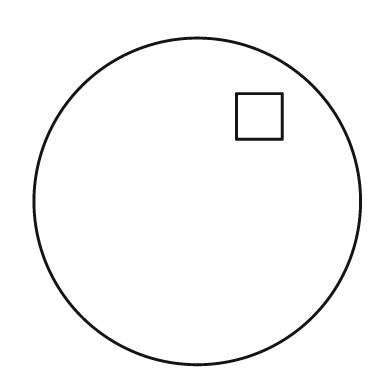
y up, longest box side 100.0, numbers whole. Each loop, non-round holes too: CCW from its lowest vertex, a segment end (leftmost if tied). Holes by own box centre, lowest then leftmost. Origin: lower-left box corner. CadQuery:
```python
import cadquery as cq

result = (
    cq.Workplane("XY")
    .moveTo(50.0, 50.0)
    .circle(50.0)
    .moveTo(62.0, 69.0)
    .lineTo(76.0, 69.0)
    .lineTo(76.0, 83.0)
    .lineTo(62.0, 83.0)
    .close()
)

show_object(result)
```